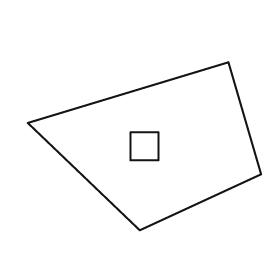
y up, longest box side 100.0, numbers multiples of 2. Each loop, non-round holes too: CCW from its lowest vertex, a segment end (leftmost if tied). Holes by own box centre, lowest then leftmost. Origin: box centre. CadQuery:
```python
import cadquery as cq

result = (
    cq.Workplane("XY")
    .moveTo(-2.0, -36.0)
    .lineTo(50.0, -12.0)
    .lineTo(36.0, 36.0)
    .lineTo(-50.0, 10.0)
    .close()
    .moveTo(-6.0, -6.0)
    .lineTo(6.0, -6.0)
    .lineTo(6.0, 6.0)
    .lineTo(-6.0, 6.0)
    .close()
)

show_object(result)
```